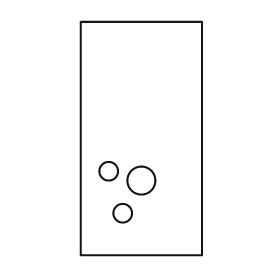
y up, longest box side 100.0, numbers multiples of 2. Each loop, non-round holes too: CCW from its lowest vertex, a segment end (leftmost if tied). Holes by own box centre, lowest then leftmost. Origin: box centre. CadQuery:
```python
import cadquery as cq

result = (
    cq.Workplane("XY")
    .moveTo(-26.0, -50.0)
    .lineTo(26.0, -50.0)
    .lineTo(26.0, 50.0)
    .lineTo(-26.0, 50.0)
    .close()
    .moveTo(-8.0, -32.0)
    .circle(4.0)
    .moveTo(0.0, -18.0)
    .circle(6.0)
    .moveTo(-14.0, -14.0)
    .circle(4.0)
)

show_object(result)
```